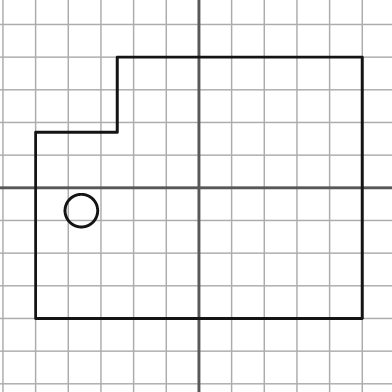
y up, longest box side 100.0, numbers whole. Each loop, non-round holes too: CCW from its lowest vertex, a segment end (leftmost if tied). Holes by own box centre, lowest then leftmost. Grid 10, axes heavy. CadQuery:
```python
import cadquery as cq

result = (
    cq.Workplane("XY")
    .moveTo(-50.0, -40.0)
    .lineTo(50.0, -40.0)
    .lineTo(50.0, 40.0)
    .lineTo(-25.0, 40.0)
    .lineTo(-25.0, 17.0)
    .lineTo(-50.0, 17.0)
    .close()
    .moveTo(-36.0, -7.0)
    .circle(5.0)
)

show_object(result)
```